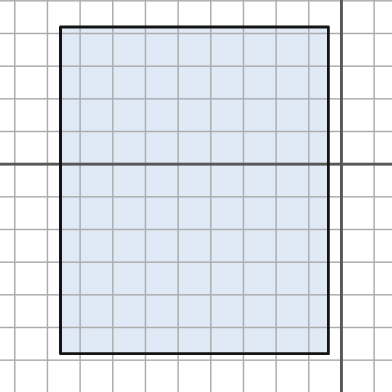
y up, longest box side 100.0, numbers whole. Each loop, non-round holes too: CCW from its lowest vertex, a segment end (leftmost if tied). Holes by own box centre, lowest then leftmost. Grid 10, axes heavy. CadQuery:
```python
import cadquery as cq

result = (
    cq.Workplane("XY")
    .moveTo(-86.0, -58.0)
    .lineTo(-4.0, -58.0)
    .lineTo(-4.0, 42.0)
    .lineTo(-86.0, 42.0)
    .close()
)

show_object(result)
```